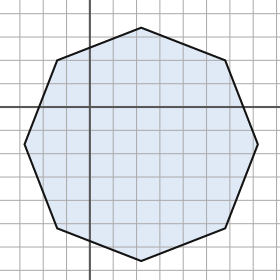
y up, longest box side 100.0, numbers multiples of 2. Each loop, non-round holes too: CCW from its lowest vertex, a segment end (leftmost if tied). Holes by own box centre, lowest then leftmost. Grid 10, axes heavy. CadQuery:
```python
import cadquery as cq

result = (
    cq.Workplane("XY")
    .moveTo(22.0, -66.0)
    .lineTo(58.0, -52.0)
    .lineTo(72.0, -16.0)
    .lineTo(58.0, 20.0)
    .lineTo(22.0, 34.0)
    .lineTo(-14.0, 20.0)
    .lineTo(-28.0, -16.0)
    .lineTo(-14.0, -52.0)
    .close()
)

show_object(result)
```